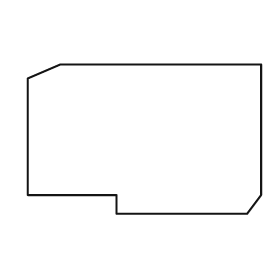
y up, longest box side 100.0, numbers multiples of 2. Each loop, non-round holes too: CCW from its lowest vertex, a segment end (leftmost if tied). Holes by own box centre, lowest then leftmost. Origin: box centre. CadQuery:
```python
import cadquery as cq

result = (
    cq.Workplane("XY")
    .moveTo(-12.0, -32.0)
    .lineTo(44.0, -32.0)
    .lineTo(50.0, -24.0)
    .lineTo(50.0, 32.0)
    .lineTo(-36.0, 32.0)
    .lineTo(-50.0, 26.0)
    .lineTo(-50.0, -24.0)
    .lineTo(-12.0, -24.0)
    .close()
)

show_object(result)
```